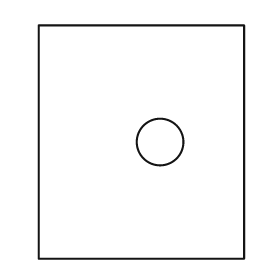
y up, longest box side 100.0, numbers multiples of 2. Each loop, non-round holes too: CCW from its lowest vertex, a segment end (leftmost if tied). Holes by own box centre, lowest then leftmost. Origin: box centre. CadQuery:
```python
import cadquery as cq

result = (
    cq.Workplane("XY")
    .moveTo(-44.0, -50.0)
    .lineTo(44.0, -50.0)
    .lineTo(44.0, 50.0)
    .lineTo(-44.0, 50.0)
    .close()
    .moveTo(8.0, 0.0)
    .circle(10.0)
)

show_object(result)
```